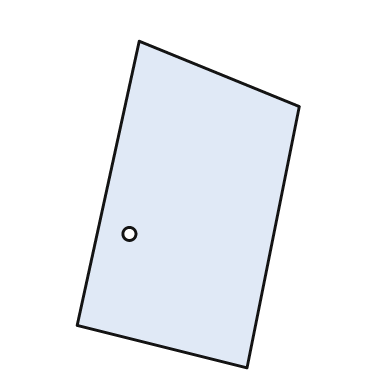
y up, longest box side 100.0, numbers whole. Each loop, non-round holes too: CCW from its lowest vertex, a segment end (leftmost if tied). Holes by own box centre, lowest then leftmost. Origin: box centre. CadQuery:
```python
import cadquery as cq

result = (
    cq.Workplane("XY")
    .moveTo(18.0, -50.0)
    .lineTo(34.0, 30.0)
    .lineTo(-15.0, 50.0)
    .lineTo(-34.0, -37.0)
    .close()
    .moveTo(-18.0, -9.0)
    .circle(2.0)
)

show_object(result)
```